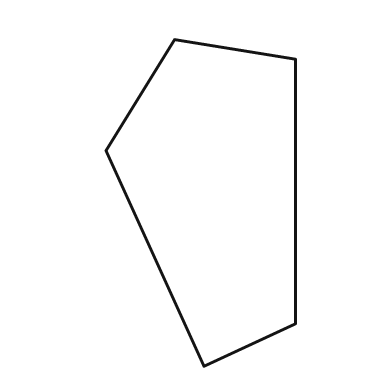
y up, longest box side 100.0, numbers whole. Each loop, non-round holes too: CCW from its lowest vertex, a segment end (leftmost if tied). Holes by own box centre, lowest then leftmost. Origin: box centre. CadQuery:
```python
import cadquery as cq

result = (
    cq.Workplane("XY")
    .moveTo(1.0, -50.0)
    .lineTo(29.0, -37.0)
    .lineTo(29.0, 44.0)
    .lineTo(-8.0, 50.0)
    .lineTo(-29.0, 16.0)
    .close()
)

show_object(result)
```